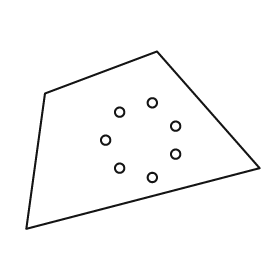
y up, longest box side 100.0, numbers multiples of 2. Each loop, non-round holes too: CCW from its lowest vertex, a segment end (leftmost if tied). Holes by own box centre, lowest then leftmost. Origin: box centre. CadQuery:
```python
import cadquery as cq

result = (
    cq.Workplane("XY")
    .moveTo(-50.0, -38.0)
    .lineTo(50.0, -12.0)
    .lineTo(6.0, 38.0)
    .lineTo(-42.0, 20.0)
    .close()
    .moveTo(4.0, -16.0)
    .circle(2.0)
    .moveTo(-10.0, -12.0)
    .circle(2.0)
    .moveTo(14.0, -6.0)
    .circle(2.0)
    .moveTo(-16.0, 0.0)
    .circle(2.0)
    .moveTo(14.0, 6.0)
    .circle(2.0)
    .moveTo(-10.0, 12.0)
    .circle(2.0)
    .moveTo(4.0, 16.0)
    .circle(2.0)
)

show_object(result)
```